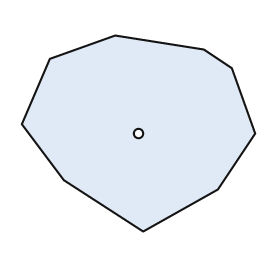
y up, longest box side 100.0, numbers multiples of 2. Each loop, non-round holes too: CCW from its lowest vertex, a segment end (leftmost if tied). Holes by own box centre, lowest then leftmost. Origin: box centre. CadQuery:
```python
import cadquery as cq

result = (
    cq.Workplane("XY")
    .moveTo(2.0, -42.0)
    .lineTo(34.0, -24.0)
    .lineTo(50.0, 0.0)
    .lineTo(40.0, 28.0)
    .lineTo(28.0, 36.0)
    .lineTo(-10.0, 42.0)
    .lineTo(-38.0, 32.0)
    .lineTo(-50.0, 4.0)
    .lineTo(-32.0, -20.0)
    .close()
    .moveTo(0.0, 0.0)
    .circle(2.0)
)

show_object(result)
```